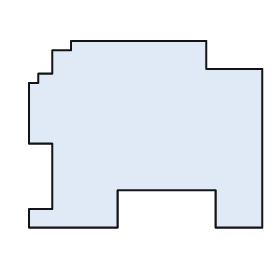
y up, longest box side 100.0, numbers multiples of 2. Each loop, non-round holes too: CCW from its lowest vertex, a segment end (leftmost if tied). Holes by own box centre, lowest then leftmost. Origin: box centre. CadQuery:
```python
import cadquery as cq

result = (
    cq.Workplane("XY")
    .moveTo(-50.0, -40.0)
    .lineTo(-12.0, -40.0)
    .lineTo(-12.0, -24.0)
    .lineTo(30.0, -24.0)
    .lineTo(30.0, -40.0)
    .lineTo(50.0, -40.0)
    .lineTo(50.0, 28.0)
    .lineTo(26.0, 28.0)
    .lineTo(26.0, 40.0)
    .lineTo(-32.0, 40.0)
    .lineTo(-32.0, 36.0)
    .lineTo(-40.0, 36.0)
    .lineTo(-40.0, 26.0)
    .lineTo(-46.0, 26.0)
    .lineTo(-46.0, 22.0)
    .lineTo(-50.0, 22.0)
    .lineTo(-50.0, -4.0)
    .lineTo(-40.0, -4.0)
    .lineTo(-40.0, -32.0)
    .lineTo(-50.0, -32.0)
    .close()
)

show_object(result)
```